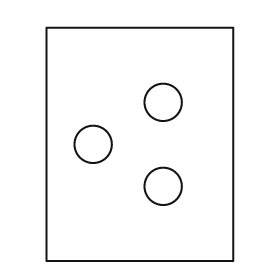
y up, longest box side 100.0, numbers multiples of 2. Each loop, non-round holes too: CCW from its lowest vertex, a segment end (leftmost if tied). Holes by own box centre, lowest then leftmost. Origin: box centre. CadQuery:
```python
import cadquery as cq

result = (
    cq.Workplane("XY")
    .moveTo(-40.0, -50.0)
    .lineTo(40.0, -50.0)
    .lineTo(40.0, 50.0)
    .lineTo(-40.0, 50.0)
    .close()
    .moveTo(10.0, -18.0)
    .circle(8.0)
    .moveTo(-20.0, 0.0)
    .circle(8.0)
    .moveTo(10.0, 18.0)
    .circle(8.0)
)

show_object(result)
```